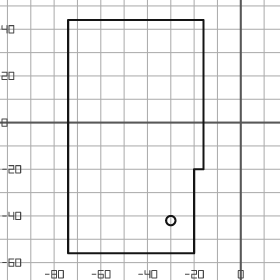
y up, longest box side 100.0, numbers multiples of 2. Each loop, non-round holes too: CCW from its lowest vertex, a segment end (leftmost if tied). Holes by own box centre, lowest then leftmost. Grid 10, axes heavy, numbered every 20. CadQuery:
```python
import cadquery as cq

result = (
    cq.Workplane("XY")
    .moveTo(-74.0, -56.0)
    .lineTo(-20.0, -56.0)
    .lineTo(-20.0, -20.0)
    .lineTo(-16.0, -20.0)
    .lineTo(-16.0, 44.0)
    .lineTo(-74.0, 44.0)
    .close()
    .moveTo(-30.0, -42.0)
    .circle(2.0)
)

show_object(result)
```